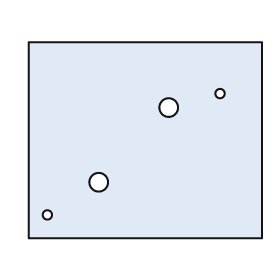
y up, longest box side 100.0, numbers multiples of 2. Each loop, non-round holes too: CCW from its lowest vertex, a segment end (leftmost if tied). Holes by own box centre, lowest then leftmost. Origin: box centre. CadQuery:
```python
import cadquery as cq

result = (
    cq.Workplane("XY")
    .moveTo(-50.0, -42.0)
    .lineTo(50.0, -42.0)
    .lineTo(50.0, 42.0)
    .lineTo(-50.0, 42.0)
    .close()
    .moveTo(-42.0, -32.0)
    .circle(2.0)
    .moveTo(-20.0, -18.0)
    .circle(4.0)
    .moveTo(10.0, 14.0)
    .circle(4.0)
    .moveTo(32.0, 20.0)
    .circle(2.0)
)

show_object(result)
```